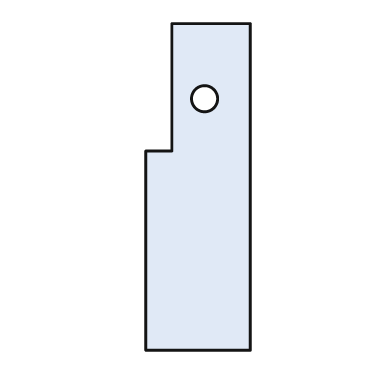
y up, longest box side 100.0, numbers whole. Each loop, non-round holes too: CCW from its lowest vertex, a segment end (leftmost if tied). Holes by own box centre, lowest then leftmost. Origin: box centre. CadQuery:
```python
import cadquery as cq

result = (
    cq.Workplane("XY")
    .moveTo(-16.0, -50.0)
    .lineTo(16.0, -50.0)
    .lineTo(16.0, 50.0)
    .lineTo(-8.0, 50.0)
    .lineTo(-8.0, 11.0)
    .lineTo(-16.0, 11.0)
    .close()
    .moveTo(2.0, 27.0)
    .circle(4.0)
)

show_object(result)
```